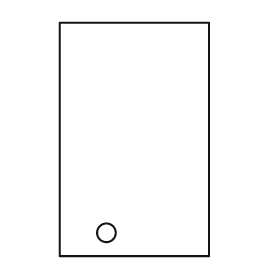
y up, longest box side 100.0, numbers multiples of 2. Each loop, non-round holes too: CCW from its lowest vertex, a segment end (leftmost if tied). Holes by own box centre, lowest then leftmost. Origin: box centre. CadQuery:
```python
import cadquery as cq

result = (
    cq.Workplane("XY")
    .moveTo(-32.0, -50.0)
    .lineTo(32.0, -50.0)
    .lineTo(32.0, 50.0)
    .lineTo(-32.0, 50.0)
    .close()
    .moveTo(-12.0, -40.0)
    .circle(4.0)
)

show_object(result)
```